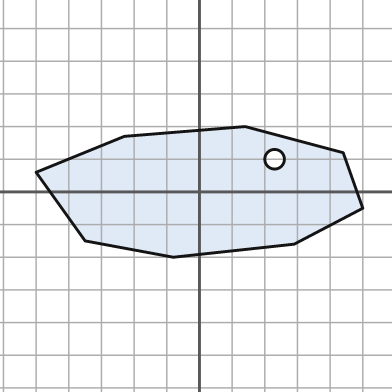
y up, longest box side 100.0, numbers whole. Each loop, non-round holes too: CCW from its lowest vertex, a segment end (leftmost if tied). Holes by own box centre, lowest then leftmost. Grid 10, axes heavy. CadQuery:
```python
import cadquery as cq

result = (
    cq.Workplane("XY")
    .moveTo(-8.0, -20.0)
    .lineTo(29.0, -16.0)
    .lineTo(50.0, -5.0)
    .lineTo(44.0, 12.0)
    .lineTo(14.0, 20.0)
    .lineTo(-23.0, 17.0)
    .lineTo(-50.0, 6.0)
    .lineTo(-35.0, -15.0)
    .close()
    .moveTo(23.0, 10.0)
    .circle(3.0)
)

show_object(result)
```